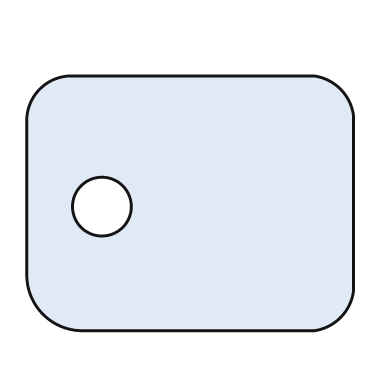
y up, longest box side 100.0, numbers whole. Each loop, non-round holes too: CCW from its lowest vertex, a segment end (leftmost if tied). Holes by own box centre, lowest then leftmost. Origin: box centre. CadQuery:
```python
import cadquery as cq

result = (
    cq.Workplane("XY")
    .moveTo(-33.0, -39.0)
    .lineTo(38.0, -39.0)
    .threePointArc((46.0, -35.0), (50.0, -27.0))
    .lineTo(50.0, 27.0)
    .threePointArc((46.0, 35.0), (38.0, 39.0))
    .lineTo(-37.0, 39.0)
    .threePointArc((-46.0, 35.0), (-50.0, 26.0))
    .lineTo(-50.0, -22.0)
    .threePointArc((-45.0, -34.0), (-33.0, -39.0))
    .close()
    .moveTo(-27.0, -1.0)
    .circle(9.0)
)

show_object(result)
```